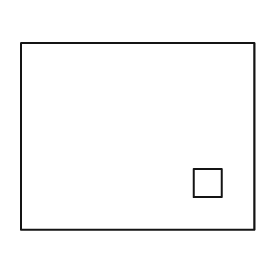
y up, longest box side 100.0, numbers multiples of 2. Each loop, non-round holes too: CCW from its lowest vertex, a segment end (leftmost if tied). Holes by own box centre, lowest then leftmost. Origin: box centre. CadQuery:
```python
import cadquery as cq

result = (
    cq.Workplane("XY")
    .moveTo(-50.0, -40.0)
    .lineTo(50.0, -40.0)
    .lineTo(50.0, 40.0)
    .lineTo(-50.0, 40.0)
    .close()
    .moveTo(24.0, -26.0)
    .lineTo(36.0, -26.0)
    .lineTo(36.0, -14.0)
    .lineTo(24.0, -14.0)
    .close()
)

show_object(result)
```